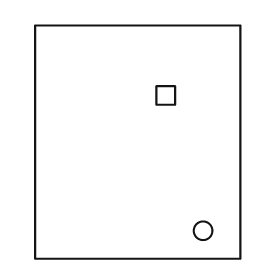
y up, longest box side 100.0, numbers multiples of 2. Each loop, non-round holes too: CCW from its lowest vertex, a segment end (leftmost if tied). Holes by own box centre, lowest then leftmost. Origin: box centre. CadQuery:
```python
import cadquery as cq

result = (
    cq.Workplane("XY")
    .moveTo(-44.0, -50.0)
    .lineTo(44.0, -50.0)
    .lineTo(44.0, 50.0)
    .lineTo(-44.0, 50.0)
    .close()
    .moveTo(28.0, -38.0)
    .circle(4.0)
    .moveTo(8.0, 16.0)
    .lineTo(16.0, 16.0)
    .lineTo(16.0, 24.0)
    .lineTo(8.0, 24.0)
    .close()
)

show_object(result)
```